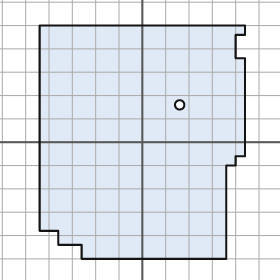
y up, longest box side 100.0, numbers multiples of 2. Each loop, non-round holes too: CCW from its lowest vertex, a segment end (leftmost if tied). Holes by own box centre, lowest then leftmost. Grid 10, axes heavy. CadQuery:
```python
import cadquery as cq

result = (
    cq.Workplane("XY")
    .moveTo(-26.0, -50.0)
    .lineTo(36.0, -50.0)
    .lineTo(36.0, -10.0)
    .lineTo(40.0, -10.0)
    .lineTo(40.0, -6.0)
    .lineTo(44.0, -6.0)
    .lineTo(44.0, 36.0)
    .lineTo(40.0, 36.0)
    .lineTo(40.0, 46.0)
    .lineTo(44.0, 46.0)
    .lineTo(44.0, 50.0)
    .lineTo(-44.0, 50.0)
    .lineTo(-44.0, -38.0)
    .lineTo(-36.0, -38.0)
    .lineTo(-36.0, -44.0)
    .lineTo(-26.0, -44.0)
    .close()
    .moveTo(16.0, 16.0)
    .circle(2.0)
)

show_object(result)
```